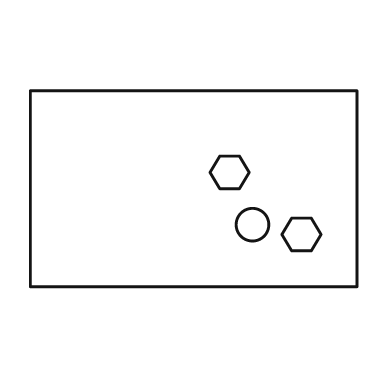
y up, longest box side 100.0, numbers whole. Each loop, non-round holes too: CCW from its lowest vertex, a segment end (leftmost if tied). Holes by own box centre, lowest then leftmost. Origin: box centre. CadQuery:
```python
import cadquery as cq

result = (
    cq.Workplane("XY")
    .moveTo(-50.0, -30.0)
    .lineTo(50.0, -30.0)
    .lineTo(50.0, 30.0)
    .lineTo(-50.0, 30.0)
    .close()
    .moveTo(30.0, -19.0)
    .lineTo(36.0, -19.0)
    .lineTo(39.0, -14.0)
    .lineTo(36.0, -9.0)
    .lineTo(30.0, -9.0)
    .lineTo(27.0, -14.0)
    .close()
    .moveTo(18.0, -11.0)
    .circle(5.0)
    .moveTo(8.0, 0.0)
    .lineTo(14.0, 0.0)
    .lineTo(17.0, 5.0)
    .lineTo(14.0, 10.0)
    .lineTo(8.0, 10.0)
    .lineTo(5.0, 5.0)
    .close()
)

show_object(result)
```